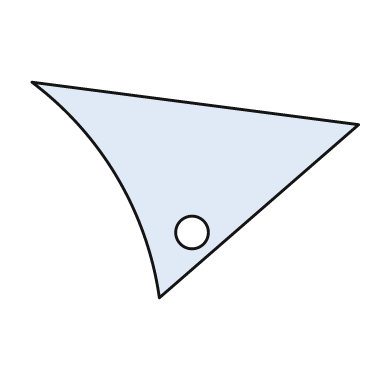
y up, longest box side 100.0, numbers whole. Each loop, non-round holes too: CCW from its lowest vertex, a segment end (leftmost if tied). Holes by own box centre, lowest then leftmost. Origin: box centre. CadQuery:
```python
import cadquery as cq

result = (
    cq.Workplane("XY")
    .moveTo(-11.0, -33.0)
    .lineTo(50.0, 20.0)
    .lineTo(-50.0, 33.0)
    .threePointArc((-24.0, 4.0), (-11.0, -33.0))
    .close()
    .moveTo(-1.0, -13.0)
    .circle(5.0)
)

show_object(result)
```